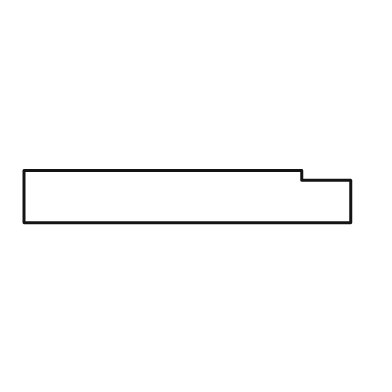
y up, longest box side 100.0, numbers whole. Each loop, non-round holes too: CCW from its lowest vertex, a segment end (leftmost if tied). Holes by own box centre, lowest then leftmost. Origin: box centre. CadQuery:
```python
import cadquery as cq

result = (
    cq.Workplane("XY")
    .moveTo(-50.0, -8.0)
    .lineTo(50.0, -8.0)
    .lineTo(50.0, 5.0)
    .lineTo(35.0, 5.0)
    .lineTo(35.0, 8.0)
    .lineTo(-50.0, 8.0)
    .close()
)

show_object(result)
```